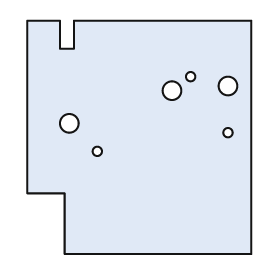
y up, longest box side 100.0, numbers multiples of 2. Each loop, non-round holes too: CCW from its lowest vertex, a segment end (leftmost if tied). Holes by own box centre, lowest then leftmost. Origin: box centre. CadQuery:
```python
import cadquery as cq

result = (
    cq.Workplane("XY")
    .moveTo(-32.0, -50.0)
    .lineTo(48.0, -50.0)
    .lineTo(48.0, 50.0)
    .lineTo(-28.0, 50.0)
    .lineTo(-28.0, 38.0)
    .lineTo(-34.0, 38.0)
    .lineTo(-34.0, 50.0)
    .lineTo(-48.0, 50.0)
    .lineTo(-48.0, -24.0)
    .lineTo(-32.0, -24.0)
    .close()
    .moveTo(-18.0, -6.0)
    .circle(2.0)
    .moveTo(38.0, 2.0)
    .circle(2.0)
    .moveTo(-30.0, 6.0)
    .circle(4.0)
    .moveTo(14.0, 20.0)
    .circle(4.0)
    .moveTo(38.0, 22.0)
    .circle(4.0)
    .moveTo(22.0, 26.0)
    .circle(2.0)
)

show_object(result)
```